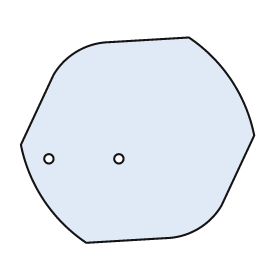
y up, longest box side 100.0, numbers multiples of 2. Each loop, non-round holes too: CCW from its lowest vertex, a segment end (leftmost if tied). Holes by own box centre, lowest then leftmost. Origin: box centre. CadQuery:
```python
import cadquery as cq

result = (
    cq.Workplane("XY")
    .moveTo(-22.0, -44.0)
    .lineTo(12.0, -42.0)
    .threePointArc((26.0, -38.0), (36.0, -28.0))
    .lineTo(50.0, 2.0)
    .threePointArc((40.0, 26.0), (22.0, 44.0))
    .lineTo(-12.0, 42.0)
    .threePointArc((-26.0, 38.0), (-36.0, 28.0))
    .lineTo(-50.0, -2.0)
    .threePointArc((-40.0, -26.0), (-22.0, -44.0))
    .close()
    .moveTo(-38.0, -8.0)
    .circle(2.0)
    .moveTo(-8.0, -8.0)
    .circle(2.0)
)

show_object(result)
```